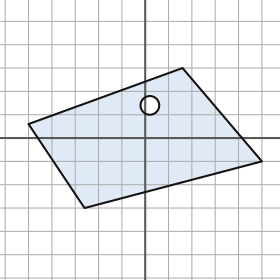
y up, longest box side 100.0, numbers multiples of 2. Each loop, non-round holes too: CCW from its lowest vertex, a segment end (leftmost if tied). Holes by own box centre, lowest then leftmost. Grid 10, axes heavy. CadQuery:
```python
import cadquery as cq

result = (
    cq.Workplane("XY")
    .moveTo(-26.0, -30.0)
    .lineTo(50.0, -10.0)
    .lineTo(16.0, 30.0)
    .lineTo(-50.0, 6.0)
    .close()
    .moveTo(2.0, 14.0)
    .circle(4.0)
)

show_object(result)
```